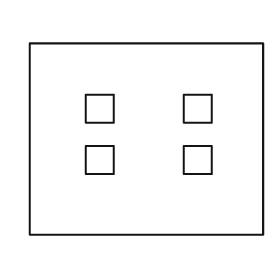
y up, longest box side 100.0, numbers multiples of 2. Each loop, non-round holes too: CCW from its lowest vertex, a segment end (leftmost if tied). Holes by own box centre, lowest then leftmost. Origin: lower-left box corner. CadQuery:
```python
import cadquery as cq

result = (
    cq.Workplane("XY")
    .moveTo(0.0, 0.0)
    .lineTo(100.0, 0.0)
    .lineTo(100.0, 82.0)
    .lineTo(0.0, 82.0)
    .close()
    .moveTo(24.0, 26.0)
    .lineTo(36.0, 26.0)
    .lineTo(36.0, 38.0)
    .lineTo(24.0, 38.0)
    .close()
    .moveTo(66.0, 26.0)
    .lineTo(78.0, 26.0)
    .lineTo(78.0, 38.0)
    .lineTo(66.0, 38.0)
    .close()
    .moveTo(24.0, 48.0)
    .lineTo(36.0, 48.0)
    .lineTo(36.0, 60.0)
    .lineTo(24.0, 60.0)
    .close()
    .moveTo(66.0, 48.0)
    .lineTo(78.0, 48.0)
    .lineTo(78.0, 60.0)
    .lineTo(66.0, 60.0)
    .close()
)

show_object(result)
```